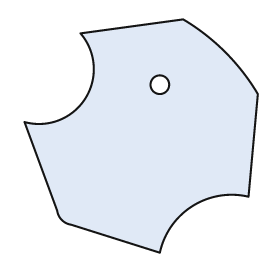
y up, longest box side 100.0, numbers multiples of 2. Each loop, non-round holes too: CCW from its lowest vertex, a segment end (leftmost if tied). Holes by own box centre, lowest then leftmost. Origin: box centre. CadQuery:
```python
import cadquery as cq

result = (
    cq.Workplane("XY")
    .moveTo(8.0, -50.0)
    .threePointArc((22.0, -30.0), (46.0, -26.0))
    .lineTo(50.0, 18.0)
    .threePointArc((36.0, 36.0), (18.0, 50.0))
    .lineTo(-26.0, 44.0)
    .threePointArc((-24.0, 16.0), (-50.0, 6.0))
    .lineTo(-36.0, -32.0)
    .threePointArc((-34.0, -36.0), (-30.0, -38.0))
    .close()
    .moveTo(8.0, 22.0)
    .circle(4.0)
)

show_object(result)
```